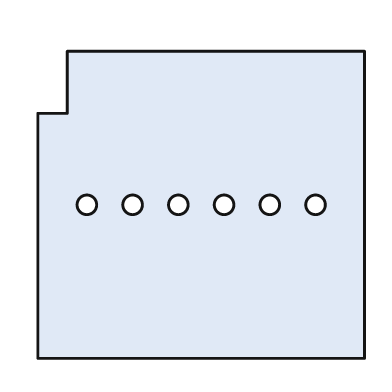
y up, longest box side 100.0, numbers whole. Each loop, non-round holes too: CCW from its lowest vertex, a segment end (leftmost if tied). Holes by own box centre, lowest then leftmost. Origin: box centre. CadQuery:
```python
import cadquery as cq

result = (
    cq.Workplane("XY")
    .moveTo(-50.0, -47.0)
    .lineTo(50.0, -47.0)
    .lineTo(50.0, 47.0)
    .lineTo(-41.0, 47.0)
    .lineTo(-41.0, 28.0)
    .lineTo(-50.0, 28.0)
    .close()
    .moveTo(-35.0, 0.0)
    .circle(3.0)
    .moveTo(-21.0, 0.0)
    .circle(3.0)
    .moveTo(-7.0, 0.0)
    .circle(3.0)
    .moveTo(7.0, 0.0)
    .circle(3.0)
    .moveTo(21.0, 0.0)
    .circle(3.0)
    .moveTo(35.0, 0.0)
    .circle(3.0)
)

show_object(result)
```